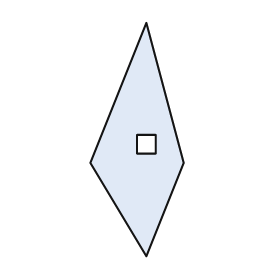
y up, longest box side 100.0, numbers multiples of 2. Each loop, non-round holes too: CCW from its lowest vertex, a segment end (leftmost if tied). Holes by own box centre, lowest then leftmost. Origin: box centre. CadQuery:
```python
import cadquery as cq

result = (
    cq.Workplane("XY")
    .moveTo(4.0, -50.0)
    .lineTo(20.0, -10.0)
    .lineTo(4.0, 50.0)
    .lineTo(-20.0, -10.0)
    .close()
    .moveTo(0.0, -6.0)
    .lineTo(8.0, -6.0)
    .lineTo(8.0, 2.0)
    .lineTo(0.0, 2.0)
    .close()
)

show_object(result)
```